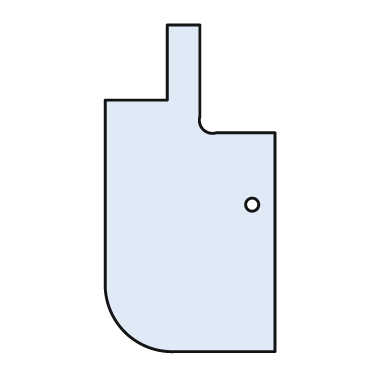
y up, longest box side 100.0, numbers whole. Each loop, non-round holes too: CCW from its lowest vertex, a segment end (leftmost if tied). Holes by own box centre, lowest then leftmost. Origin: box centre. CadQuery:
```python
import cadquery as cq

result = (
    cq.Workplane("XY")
    .moveTo(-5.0, -50.0)
    .lineTo(26.0, -50.0)
    .lineTo(26.0, 17.0)
    .lineTo(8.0, 17.0)
    .threePointArc((4.0, 18.0), (3.0, 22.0))
    .lineTo(3.0, 50.0)
    .lineTo(-7.0, 50.0)
    .lineTo(-7.0, 27.0)
    .lineTo(-26.0, 27.0)
    .lineTo(-26.0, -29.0)
    .threePointArc((-20.0, -44.0), (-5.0, -50.0))
    .close()
    .moveTo(19.0, -5.0)
    .circle(2.0)
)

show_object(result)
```